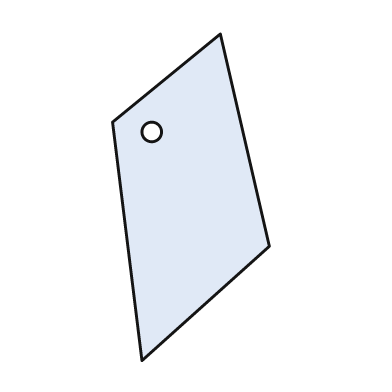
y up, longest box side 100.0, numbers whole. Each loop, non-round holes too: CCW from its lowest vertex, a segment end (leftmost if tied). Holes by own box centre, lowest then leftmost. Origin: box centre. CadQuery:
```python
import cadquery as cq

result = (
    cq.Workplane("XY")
    .moveTo(-15.0, -50.0)
    .lineTo(24.0, -15.0)
    .lineTo(9.0, 50.0)
    .lineTo(-24.0, 23.0)
    .close()
    .moveTo(-12.0, 20.0)
    .circle(3.0)
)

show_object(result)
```